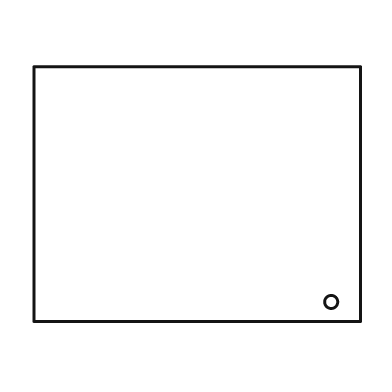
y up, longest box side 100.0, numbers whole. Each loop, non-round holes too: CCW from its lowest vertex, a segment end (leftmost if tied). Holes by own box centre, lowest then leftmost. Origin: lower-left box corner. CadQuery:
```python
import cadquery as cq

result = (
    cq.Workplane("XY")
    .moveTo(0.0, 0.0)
    .lineTo(100.0, 0.0)
    .lineTo(100.0, 78.0)
    .lineTo(0.0, 78.0)
    .close()
    .moveTo(91.0, 6.0)
    .circle(2.0)
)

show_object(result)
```